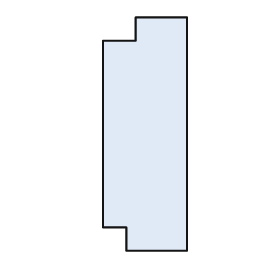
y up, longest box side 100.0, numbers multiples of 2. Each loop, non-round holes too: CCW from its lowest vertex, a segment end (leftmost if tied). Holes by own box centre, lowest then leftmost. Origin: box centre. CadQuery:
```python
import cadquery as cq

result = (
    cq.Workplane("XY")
    .moveTo(-8.0, -50.0)
    .lineTo(18.0, -50.0)
    .lineTo(18.0, 50.0)
    .lineTo(-4.0, 50.0)
    .lineTo(-4.0, 40.0)
    .lineTo(-18.0, 40.0)
    .lineTo(-18.0, -40.0)
    .lineTo(-8.0, -40.0)
    .close()
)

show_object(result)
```